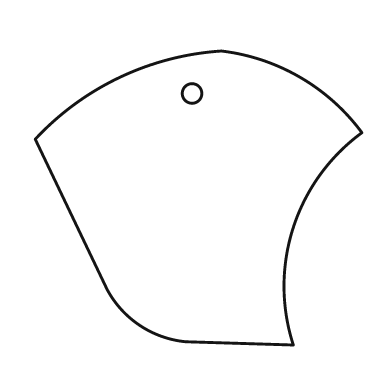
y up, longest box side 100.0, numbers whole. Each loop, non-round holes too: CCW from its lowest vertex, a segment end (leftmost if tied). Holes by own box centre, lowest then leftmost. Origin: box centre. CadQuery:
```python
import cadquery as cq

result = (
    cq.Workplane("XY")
    .moveTo(29.0, -45.0)
    .threePointArc((29.0, -9.0), (50.0, 20.0))
    .threePointArc((31.0, 37.0), (7.0, 45.0))
    .threePointArc((-24.0, 37.0), (-50.0, 18.0))
    .lineTo(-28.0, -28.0)
    .threePointArc((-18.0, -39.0), (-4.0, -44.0))
    .close()
    .moveTo(-2.0, 32.0)
    .circle(3.0)
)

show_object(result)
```